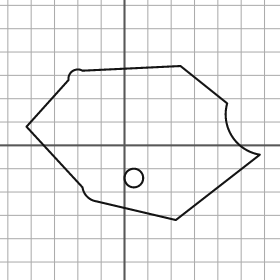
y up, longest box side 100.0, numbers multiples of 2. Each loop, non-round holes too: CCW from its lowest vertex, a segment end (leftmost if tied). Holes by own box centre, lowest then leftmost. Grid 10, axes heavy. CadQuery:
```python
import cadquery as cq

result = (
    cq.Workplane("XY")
    .moveTo(22.0, -32.0)
    .lineTo(58.0, -4.0)
    .threePointArc((46.0, 4.0), (44.0, 18.0))
    .lineTo(24.0, 34.0)
    .lineTo(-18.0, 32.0)
    .threePointArc((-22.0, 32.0), (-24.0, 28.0))
    .lineTo(-42.0, 8.0)
    .lineTo(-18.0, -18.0)
    .threePointArc((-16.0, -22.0), (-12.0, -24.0))
    .close()
    .moveTo(4.0, -14.0)
    .circle(4.0)
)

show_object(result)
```